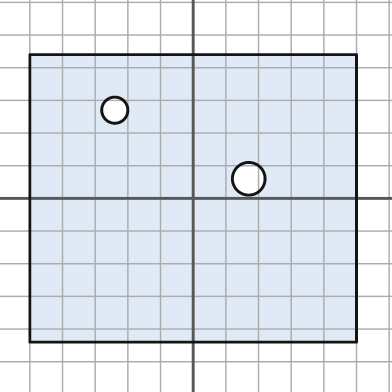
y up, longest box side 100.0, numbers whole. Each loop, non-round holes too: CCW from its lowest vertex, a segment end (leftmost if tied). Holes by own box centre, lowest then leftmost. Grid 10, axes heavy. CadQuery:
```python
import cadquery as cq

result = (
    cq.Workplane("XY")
    .moveTo(-50.0, -44.0)
    .lineTo(50.0, -44.0)
    .lineTo(50.0, 44.0)
    .lineTo(-50.0, 44.0)
    .close()
    .moveTo(17.0, 6.0)
    .circle(5.0)
    .moveTo(-24.0, 27.0)
    .circle(4.0)
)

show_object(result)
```